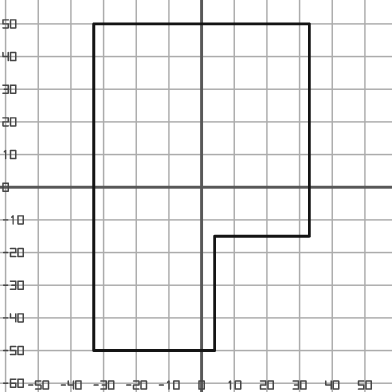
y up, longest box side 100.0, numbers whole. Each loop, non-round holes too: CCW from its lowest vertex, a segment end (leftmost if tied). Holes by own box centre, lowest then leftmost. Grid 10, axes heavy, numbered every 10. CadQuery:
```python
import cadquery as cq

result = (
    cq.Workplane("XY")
    .moveTo(-33.0, -50.0)
    .lineTo(4.0, -50.0)
    .lineTo(4.0, -15.0)
    .lineTo(33.0, -15.0)
    .lineTo(33.0, 50.0)
    .lineTo(-33.0, 50.0)
    .close()
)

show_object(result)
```